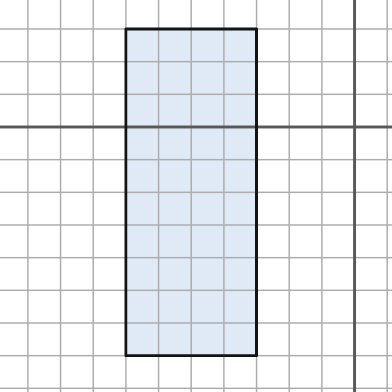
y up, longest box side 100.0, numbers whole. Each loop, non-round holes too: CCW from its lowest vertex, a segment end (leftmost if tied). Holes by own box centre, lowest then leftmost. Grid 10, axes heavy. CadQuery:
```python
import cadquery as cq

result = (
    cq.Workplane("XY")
    .moveTo(-70.0, -70.0)
    .lineTo(-30.0, -70.0)
    .lineTo(-30.0, 30.0)
    .lineTo(-70.0, 30.0)
    .close()
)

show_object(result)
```